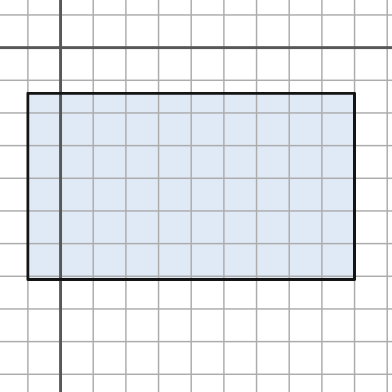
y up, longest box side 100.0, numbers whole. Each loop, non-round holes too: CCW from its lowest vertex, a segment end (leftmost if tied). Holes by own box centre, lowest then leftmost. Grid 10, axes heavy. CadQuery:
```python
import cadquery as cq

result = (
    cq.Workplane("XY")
    .moveTo(-10.0, -71.0)
    .lineTo(90.0, -71.0)
    .lineTo(90.0, -14.0)
    .lineTo(-10.0, -14.0)
    .close()
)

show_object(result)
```